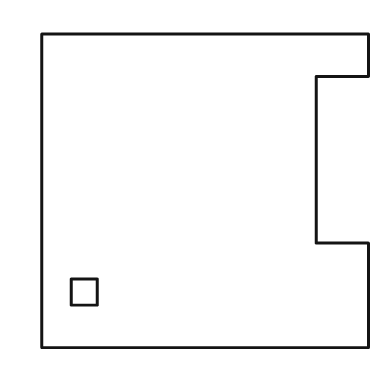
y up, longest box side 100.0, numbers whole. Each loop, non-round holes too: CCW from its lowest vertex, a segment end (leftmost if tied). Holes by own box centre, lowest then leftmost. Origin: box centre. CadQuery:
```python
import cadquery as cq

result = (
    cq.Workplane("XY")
    .moveTo(-50.0, -48.0)
    .lineTo(50.0, -48.0)
    .lineTo(50.0, -16.0)
    .lineTo(34.0, -16.0)
    .lineTo(34.0, 35.0)
    .lineTo(50.0, 35.0)
    .lineTo(50.0, 48.0)
    .lineTo(-50.0, 48.0)
    .close()
    .moveTo(-41.0, -35.0)
    .lineTo(-33.0, -35.0)
    .lineTo(-33.0, -27.0)
    .lineTo(-41.0, -27.0)
    .close()
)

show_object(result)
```